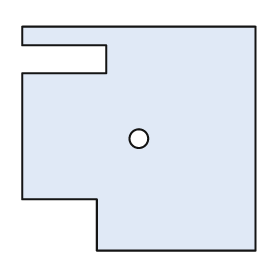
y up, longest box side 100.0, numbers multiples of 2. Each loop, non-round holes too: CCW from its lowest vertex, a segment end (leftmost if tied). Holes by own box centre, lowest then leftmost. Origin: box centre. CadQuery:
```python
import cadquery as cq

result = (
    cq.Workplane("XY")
    .moveTo(-18.0, -48.0)
    .lineTo(50.0, -48.0)
    .lineTo(50.0, 48.0)
    .lineTo(-50.0, 48.0)
    .lineTo(-50.0, 40.0)
    .lineTo(-14.0, 40.0)
    .lineTo(-14.0, 28.0)
    .lineTo(-50.0, 28.0)
    .lineTo(-50.0, -26.0)
    .lineTo(-18.0, -26.0)
    .close()
    .moveTo(0.0, 0.0)
    .circle(4.0)
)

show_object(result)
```